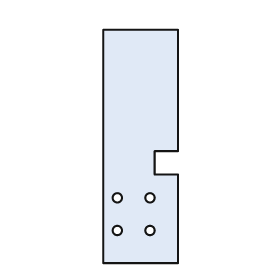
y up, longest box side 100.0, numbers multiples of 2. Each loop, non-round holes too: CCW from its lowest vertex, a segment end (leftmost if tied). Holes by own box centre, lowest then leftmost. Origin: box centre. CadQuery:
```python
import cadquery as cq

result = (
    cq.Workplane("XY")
    .moveTo(-16.0, -50.0)
    .lineTo(16.0, -50.0)
    .lineTo(16.0, -12.0)
    .lineTo(6.0, -12.0)
    .lineTo(6.0, -2.0)
    .lineTo(16.0, -2.0)
    .lineTo(16.0, 50.0)
    .lineTo(-16.0, 50.0)
    .close()
    .moveTo(-10.0, -36.0)
    .circle(2.0)
    .moveTo(4.0, -36.0)
    .circle(2.0)
    .moveTo(-10.0, -22.0)
    .circle(2.0)
    .moveTo(4.0, -22.0)
    .circle(2.0)
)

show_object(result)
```